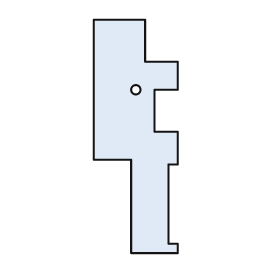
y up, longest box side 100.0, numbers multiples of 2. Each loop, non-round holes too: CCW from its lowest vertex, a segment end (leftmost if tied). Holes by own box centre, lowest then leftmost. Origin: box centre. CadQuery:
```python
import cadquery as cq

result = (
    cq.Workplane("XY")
    .moveTo(-2.0, -50.0)
    .lineTo(18.0, -50.0)
    .lineTo(18.0, -46.0)
    .lineTo(14.0, -46.0)
    .lineTo(14.0, -12.0)
    .lineTo(18.0, -12.0)
    .lineTo(18.0, 2.0)
    .lineTo(8.0, 2.0)
    .lineTo(8.0, 20.0)
    .lineTo(18.0, 20.0)
    .lineTo(18.0, 32.0)
    .lineTo(4.0, 32.0)
    .lineTo(4.0, 50.0)
    .lineTo(-18.0, 50.0)
    .lineTo(-18.0, -10.0)
    .lineTo(-2.0, -10.0)
    .close()
    .moveTo(0.0, 20.0)
    .circle(2.0)
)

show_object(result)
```